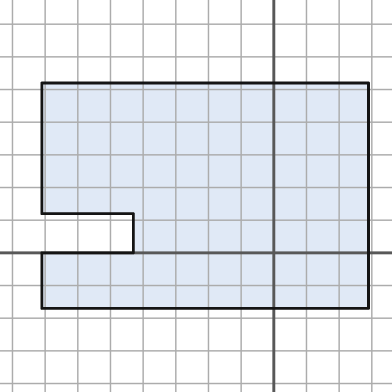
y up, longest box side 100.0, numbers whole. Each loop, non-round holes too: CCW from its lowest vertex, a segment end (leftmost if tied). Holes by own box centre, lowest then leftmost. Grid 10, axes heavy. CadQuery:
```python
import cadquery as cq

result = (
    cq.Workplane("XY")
    .moveTo(-71.0, -17.0)
    .lineTo(29.0, -17.0)
    .lineTo(29.0, 52.0)
    .lineTo(-71.0, 52.0)
    .lineTo(-71.0, 12.0)
    .lineTo(-43.0, 12.0)
    .lineTo(-43.0, 0.0)
    .lineTo(-71.0, 0.0)
    .close()
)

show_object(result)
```